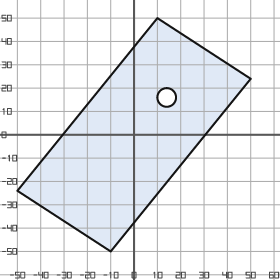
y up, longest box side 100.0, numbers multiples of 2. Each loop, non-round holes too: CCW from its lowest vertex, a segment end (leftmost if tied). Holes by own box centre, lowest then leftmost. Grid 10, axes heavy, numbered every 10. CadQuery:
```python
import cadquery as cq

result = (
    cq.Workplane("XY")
    .moveTo(-10.0, -50.0)
    .lineTo(50.0, 24.0)
    .lineTo(10.0, 50.0)
    .lineTo(-50.0, -24.0)
    .close()
    .moveTo(14.0, 16.0)
    .circle(4.0)
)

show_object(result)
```